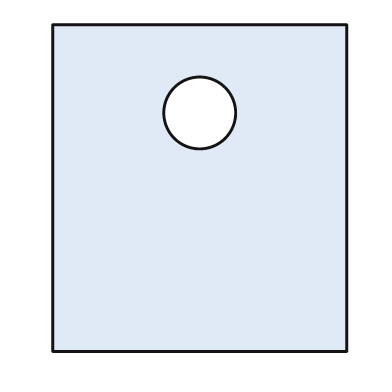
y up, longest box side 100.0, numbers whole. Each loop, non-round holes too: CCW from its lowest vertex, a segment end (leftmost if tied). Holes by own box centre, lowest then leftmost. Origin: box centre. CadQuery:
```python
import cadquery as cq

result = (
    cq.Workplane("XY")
    .moveTo(-45.0, -50.0)
    .lineTo(45.0, -50.0)
    .lineTo(45.0, 50.0)
    .lineTo(-45.0, 50.0)
    .close()
    .moveTo(0.0, 23.0)
    .circle(11.0)
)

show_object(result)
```